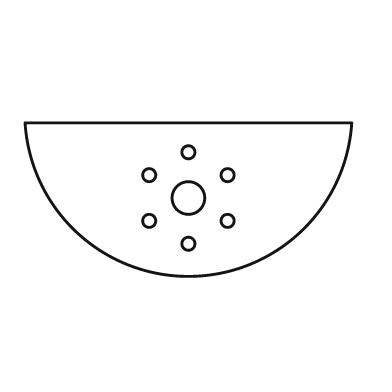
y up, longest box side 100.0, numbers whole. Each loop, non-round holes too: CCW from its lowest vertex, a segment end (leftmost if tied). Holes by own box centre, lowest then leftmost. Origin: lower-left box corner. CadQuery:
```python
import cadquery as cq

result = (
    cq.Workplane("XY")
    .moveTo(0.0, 47.0)
    .threePointArc((50.0, 0.0), (100.0, 47.0))
    .close()
    .moveTo(50.0, 10.0)
    .circle(2.0)
    .moveTo(38.0, 17.0)
    .circle(2.0)
    .moveTo(62.0, 17.0)
    .circle(2.0)
    .moveTo(50.0, 24.0)
    .circle(5.0)
    .moveTo(38.0, 31.0)
    .circle(2.0)
    .moveTo(62.0, 31.0)
    .circle(2.0)
    .moveTo(50.0, 38.0)
    .circle(2.0)
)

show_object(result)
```